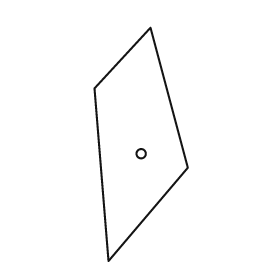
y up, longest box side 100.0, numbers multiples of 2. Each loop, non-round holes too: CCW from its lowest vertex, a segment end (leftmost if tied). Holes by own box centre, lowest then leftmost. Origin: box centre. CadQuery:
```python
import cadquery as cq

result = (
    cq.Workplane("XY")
    .moveTo(-14.0, -50.0)
    .lineTo(20.0, -10.0)
    .lineTo(4.0, 50.0)
    .lineTo(-20.0, 24.0)
    .close()
    .moveTo(0.0, -4.0)
    .circle(2.0)
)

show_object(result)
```